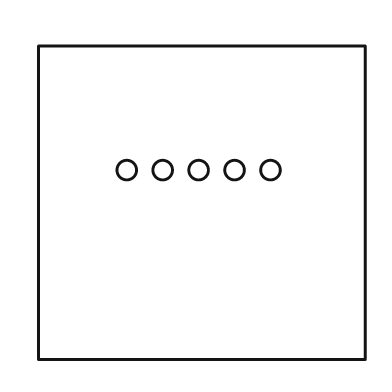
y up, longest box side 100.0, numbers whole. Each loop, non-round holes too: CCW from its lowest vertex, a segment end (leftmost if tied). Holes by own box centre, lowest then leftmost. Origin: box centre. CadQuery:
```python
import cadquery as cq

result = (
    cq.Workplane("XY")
    .moveTo(-50.0, -48.0)
    .lineTo(50.0, -48.0)
    .lineTo(50.0, 48.0)
    .lineTo(-50.0, 48.0)
    .close()
    .moveTo(-23.0, 10.0)
    .circle(3.0)
    .moveTo(-12.0, 10.0)
    .circle(3.0)
    .moveTo(-1.0, 10.0)
    .circle(3.0)
    .moveTo(10.0, 10.0)
    .circle(3.0)
    .moveTo(21.0, 10.0)
    .circle(3.0)
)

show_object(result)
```